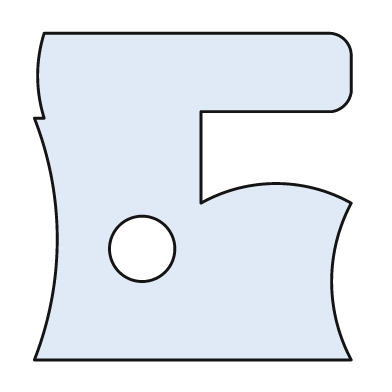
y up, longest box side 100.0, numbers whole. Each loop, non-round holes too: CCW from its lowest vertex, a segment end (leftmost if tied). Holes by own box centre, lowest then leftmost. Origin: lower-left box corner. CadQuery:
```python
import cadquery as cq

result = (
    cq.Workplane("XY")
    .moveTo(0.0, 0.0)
    .lineTo(97.0, 0.0)
    .threePointArc((91.0, 24.0), (97.0, 48.0))
    .threePointArc((74.0, 54.0), (51.0, 48.0))
    .lineTo(51.0, 76.0)
    .lineTo(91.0, 76.0)
    .threePointArc((95.0, 78.0), (97.0, 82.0))
    .lineTo(97.0, 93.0)
    .threePointArc((95.0, 98.0), (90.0, 100.0))
    .lineTo(3.0, 100.0)
    .threePointArc((1.0, 87.0), (3.0, 74.0))
    .lineTo(0.0, 74.0)
    .threePointArc((7.0, 37.0), (0.0, 0.0))
    .close()
    .moveTo(33.0, 34.0)
    .circle(10.0)
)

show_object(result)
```